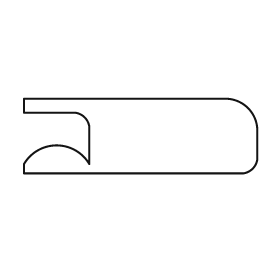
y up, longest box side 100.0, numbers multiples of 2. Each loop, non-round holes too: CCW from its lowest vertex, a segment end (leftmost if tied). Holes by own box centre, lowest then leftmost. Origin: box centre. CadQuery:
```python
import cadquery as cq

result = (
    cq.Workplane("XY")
    .moveTo(-50.0, -16.0)
    .lineTo(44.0, -16.0)
    .threePointArc((48.0, -14.0), (50.0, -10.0))
    .lineTo(50.0, 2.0)
    .threePointArc((46.0, 12.0), (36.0, 16.0))
    .lineTo(-50.0, 16.0)
    .lineTo(-50.0, 10.0)
    .lineTo(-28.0, 10.0)
    .threePointArc((-24.0, 8.0), (-22.0, 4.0))
    .lineTo(-22.0, -12.0)
    .threePointArc((-36.0, -4.0), (-50.0, -12.0))
    .close()
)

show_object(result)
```